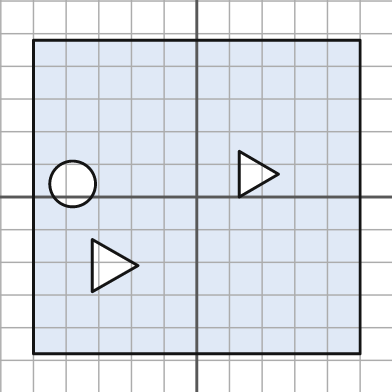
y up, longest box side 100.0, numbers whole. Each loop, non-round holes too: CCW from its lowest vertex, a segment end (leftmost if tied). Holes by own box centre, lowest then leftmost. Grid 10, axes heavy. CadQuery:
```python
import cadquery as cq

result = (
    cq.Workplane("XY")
    .moveTo(-50.0, -48.0)
    .lineTo(50.0, -48.0)
    .lineTo(50.0, 48.0)
    .lineTo(-50.0, 48.0)
    .close()
    .moveTo(-32.0, -29.0)
    .lineTo(-18.0, -21.0)
    .lineTo(-32.0, -13.0)
    .close()
    .moveTo(-38.0, 4.0)
    .circle(7.0)
    .moveTo(13.0, 0.0)
    .lineTo(25.0, 7.0)
    .lineTo(13.0, 14.0)
    .close()
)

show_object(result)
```